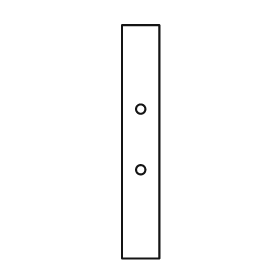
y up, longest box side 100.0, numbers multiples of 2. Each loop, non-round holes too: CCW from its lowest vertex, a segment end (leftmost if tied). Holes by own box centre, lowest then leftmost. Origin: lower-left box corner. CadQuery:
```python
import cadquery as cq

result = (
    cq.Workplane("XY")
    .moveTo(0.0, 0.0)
    .lineTo(16.0, 0.0)
    .lineTo(16.0, 100.0)
    .lineTo(0.0, 100.0)
    .close()
    .moveTo(8.0, 38.0)
    .circle(2.0)
    .moveTo(8.0, 64.0)
    .circle(2.0)
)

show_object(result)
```